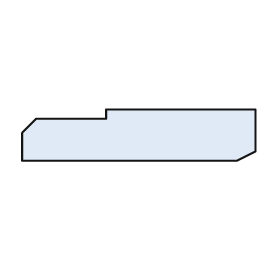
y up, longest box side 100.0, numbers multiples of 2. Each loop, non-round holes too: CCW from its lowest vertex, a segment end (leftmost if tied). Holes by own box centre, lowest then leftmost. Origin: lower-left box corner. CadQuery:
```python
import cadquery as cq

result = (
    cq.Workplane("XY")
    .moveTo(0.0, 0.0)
    .lineTo(92.0, 0.0)
    .lineTo(100.0, 4.0)
    .lineTo(100.0, 22.0)
    .lineTo(36.0, 22.0)
    .lineTo(36.0, 18.0)
    .lineTo(6.0, 18.0)
    .lineTo(0.0, 12.0)
    .close()
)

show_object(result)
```